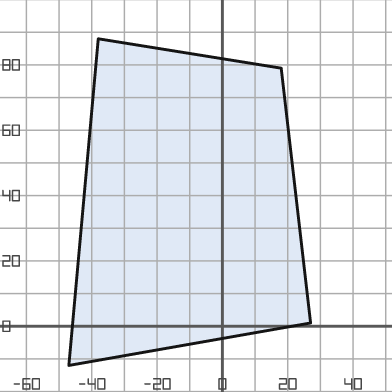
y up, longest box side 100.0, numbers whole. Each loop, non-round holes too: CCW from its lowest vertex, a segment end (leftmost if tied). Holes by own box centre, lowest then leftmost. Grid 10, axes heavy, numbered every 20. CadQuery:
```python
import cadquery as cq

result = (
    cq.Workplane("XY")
    .moveTo(-47.0, -12.0)
    .lineTo(27.0, 1.0)
    .lineTo(18.0, 79.0)
    .lineTo(-38.0, 88.0)
    .close()
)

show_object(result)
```